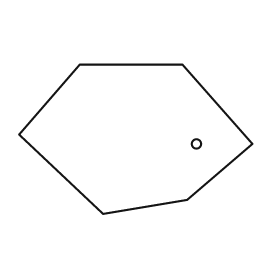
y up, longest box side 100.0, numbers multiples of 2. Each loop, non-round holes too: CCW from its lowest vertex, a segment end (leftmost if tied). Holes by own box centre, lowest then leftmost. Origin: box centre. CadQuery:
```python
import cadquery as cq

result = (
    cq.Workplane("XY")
    .moveTo(-14.0, -32.0)
    .lineTo(22.0, -26.0)
    .lineTo(50.0, -2.0)
    .lineTo(20.0, 32.0)
    .lineTo(-24.0, 32.0)
    .lineTo(-50.0, 2.0)
    .close()
    .moveTo(26.0, -2.0)
    .circle(2.0)
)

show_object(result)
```